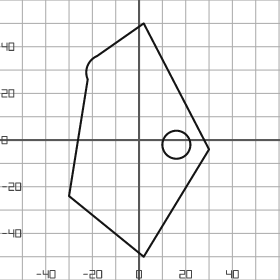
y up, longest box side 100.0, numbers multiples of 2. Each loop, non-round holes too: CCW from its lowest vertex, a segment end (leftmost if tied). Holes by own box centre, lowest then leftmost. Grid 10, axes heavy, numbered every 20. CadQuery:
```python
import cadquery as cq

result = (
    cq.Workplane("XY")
    .moveTo(2.0, -50.0)
    .lineTo(30.0, -4.0)
    .lineTo(2.0, 50.0)
    .lineTo(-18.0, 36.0)
    .threePointArc((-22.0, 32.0), (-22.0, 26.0))
    .lineTo(-30.0, -24.0)
    .close()
    .moveTo(16.0, -2.0)
    .circle(6.0)
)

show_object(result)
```